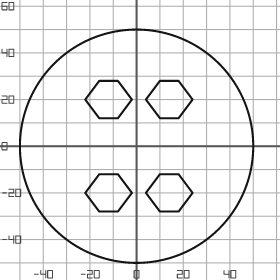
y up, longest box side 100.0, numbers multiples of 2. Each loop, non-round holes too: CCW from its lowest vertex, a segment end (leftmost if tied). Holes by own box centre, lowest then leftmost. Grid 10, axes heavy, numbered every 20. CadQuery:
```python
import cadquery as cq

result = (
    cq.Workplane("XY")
    .moveTo(0.0, 0.0)
    .circle(50.0)
    .moveTo(-16.0, -28.0)
    .lineTo(-8.0, -28.0)
    .lineTo(-2.0, -20.0)
    .lineTo(-8.0, -12.0)
    .lineTo(-16.0, -12.0)
    .lineTo(-22.0, -20.0)
    .close()
    .moveTo(10.0, -28.0)
    .lineTo(18.0, -28.0)
    .lineTo(24.0, -20.0)
    .lineTo(18.0, -12.0)
    .lineTo(10.0, -12.0)
    .lineTo(4.0, -20.0)
    .close()
    .moveTo(-16.0, 12.0)
    .lineTo(-8.0, 12.0)
    .lineTo(-2.0, 20.0)
    .lineTo(-8.0, 28.0)
    .lineTo(-16.0, 28.0)
    .lineTo(-22.0, 20.0)
    .close()
    .moveTo(10.0, 12.0)
    .lineTo(18.0, 12.0)
    .lineTo(24.0, 20.0)
    .lineTo(18.0, 28.0)
    .lineTo(10.0, 28.0)
    .lineTo(4.0, 20.0)
    .close()
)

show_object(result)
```